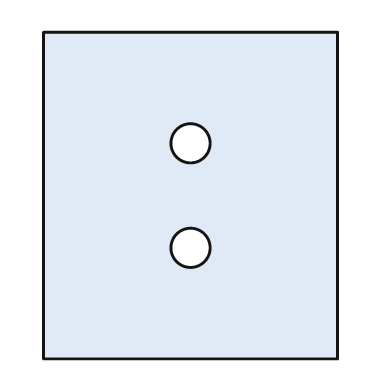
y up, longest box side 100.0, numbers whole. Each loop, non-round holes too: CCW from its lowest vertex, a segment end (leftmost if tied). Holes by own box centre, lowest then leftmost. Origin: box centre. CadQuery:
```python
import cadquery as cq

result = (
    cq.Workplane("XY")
    .moveTo(-45.0, -50.0)
    .lineTo(45.0, -50.0)
    .lineTo(45.0, 50.0)
    .lineTo(-45.0, 50.0)
    .close()
    .moveTo(0.0, -16.0)
    .circle(6.0)
    .moveTo(0.0, 16.0)
    .circle(6.0)
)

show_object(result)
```